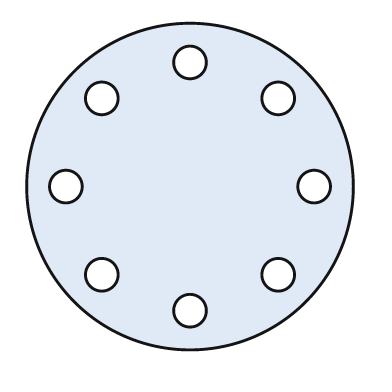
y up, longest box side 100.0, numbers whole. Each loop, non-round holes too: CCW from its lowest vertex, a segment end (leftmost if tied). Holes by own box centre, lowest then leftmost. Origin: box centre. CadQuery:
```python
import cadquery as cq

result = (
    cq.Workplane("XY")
    .moveTo(0.0, 0.0)
    .circle(50.0)
    .moveTo(0.0, -38.0)
    .circle(5.0)
    .moveTo(-27.0, -27.0)
    .circle(5.0)
    .moveTo(27.0, -27.0)
    .circle(5.0)
    .moveTo(-38.0, 0.0)
    .circle(5.0)
    .moveTo(38.0, 0.0)
    .circle(5.0)
    .moveTo(-27.0, 27.0)
    .circle(5.0)
    .moveTo(27.0, 27.0)
    .circle(5.0)
    .moveTo(0.0, 38.0)
    .circle(5.0)
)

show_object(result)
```